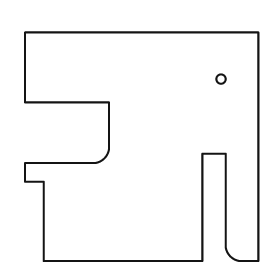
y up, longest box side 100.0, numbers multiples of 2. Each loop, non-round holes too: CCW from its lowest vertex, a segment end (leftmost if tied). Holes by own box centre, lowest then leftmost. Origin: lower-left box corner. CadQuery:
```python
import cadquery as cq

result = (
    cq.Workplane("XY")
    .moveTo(8.0, 0.0)
    .lineTo(76.0, 0.0)
    .lineTo(76.0, 46.0)
    .lineTo(86.0, 46.0)
    .lineTo(86.0, 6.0)
    .threePointArc((88.0, 2.0), (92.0, 0.0))
    .lineTo(100.0, 0.0)
    .lineTo(100.0, 98.0)
    .lineTo(0.0, 98.0)
    .lineTo(0.0, 68.0)
    .lineTo(36.0, 68.0)
    .lineTo(36.0, 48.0)
    .threePointArc((34.0, 44.0), (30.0, 42.0))
    .lineTo(0.0, 42.0)
    .lineTo(0.0, 34.0)
    .lineTo(8.0, 34.0)
    .close()
    .moveTo(84.0, 78.0)
    .circle(2.0)
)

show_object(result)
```